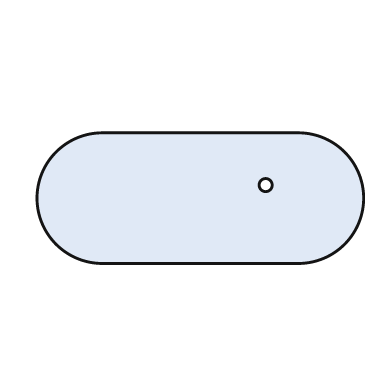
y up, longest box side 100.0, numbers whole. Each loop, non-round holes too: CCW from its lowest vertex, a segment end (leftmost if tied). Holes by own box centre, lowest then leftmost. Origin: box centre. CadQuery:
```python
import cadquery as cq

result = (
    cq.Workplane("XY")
    .moveTo(-30.0, -20.0)
    .lineTo(30.0, -20.0)
    .threePointArc((50.0, 0.0), (30.0, 20.0))
    .lineTo(-30.0, 20.0)
    .threePointArc((-50.0, 0.0), (-30.0, -20.0))
    .close()
    .moveTo(20.0, 4.0)
    .circle(2.0)
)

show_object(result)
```